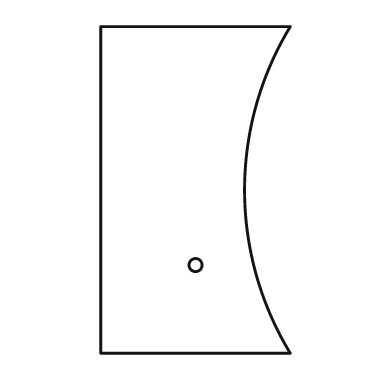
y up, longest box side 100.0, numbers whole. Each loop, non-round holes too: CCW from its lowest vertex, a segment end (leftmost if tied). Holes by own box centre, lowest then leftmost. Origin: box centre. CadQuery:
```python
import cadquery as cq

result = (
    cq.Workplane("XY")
    .moveTo(-29.0, -50.0)
    .lineTo(29.0, -50.0)
    .threePointArc((15.0, 0.0), (29.0, 50.0))
    .lineTo(-29.0, 50.0)
    .close()
    .moveTo(0.0, -23.0)
    .circle(2.0)
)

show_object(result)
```